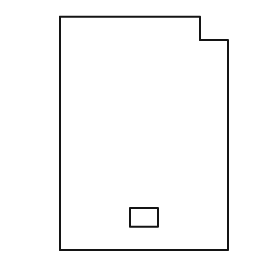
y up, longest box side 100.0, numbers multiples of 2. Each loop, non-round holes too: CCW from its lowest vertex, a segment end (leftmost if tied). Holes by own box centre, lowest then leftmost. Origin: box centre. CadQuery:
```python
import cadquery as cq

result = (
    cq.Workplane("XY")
    .moveTo(-36.0, -50.0)
    .lineTo(36.0, -50.0)
    .lineTo(36.0, 40.0)
    .lineTo(24.0, 40.0)
    .lineTo(24.0, 50.0)
    .lineTo(-36.0, 50.0)
    .close()
    .moveTo(-6.0, -40.0)
    .lineTo(6.0, -40.0)
    .lineTo(6.0, -32.0)
    .lineTo(-6.0, -32.0)
    .close()
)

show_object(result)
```